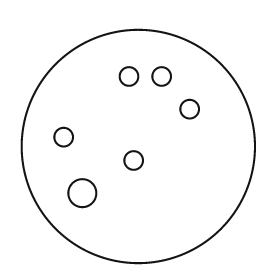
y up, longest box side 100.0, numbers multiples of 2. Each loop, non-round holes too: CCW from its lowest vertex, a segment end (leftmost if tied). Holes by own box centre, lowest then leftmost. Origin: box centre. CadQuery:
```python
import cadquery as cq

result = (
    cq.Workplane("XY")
    .moveTo(0.0, 0.0)
    .circle(50.0)
    .moveTo(-24.0, -20.0)
    .circle(6.0)
    .moveTo(-2.0, -6.0)
    .circle(4.0)
    .moveTo(-32.0, 4.0)
    .circle(4.0)
    .moveTo(22.0, 16.0)
    .circle(4.0)
    .moveTo(-4.0, 30.0)
    .circle(4.0)
    .moveTo(10.0, 30.0)
    .circle(4.0)
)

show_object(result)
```